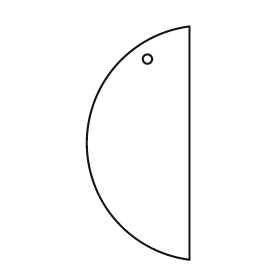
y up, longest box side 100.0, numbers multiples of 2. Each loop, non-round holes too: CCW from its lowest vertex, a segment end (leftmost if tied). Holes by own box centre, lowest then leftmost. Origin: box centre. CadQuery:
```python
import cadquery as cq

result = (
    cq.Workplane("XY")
    .moveTo(22.0, -50.0)
    .lineTo(22.0, 50.0)
    .threePointArc((-22.0, 0.0), (22.0, -50.0))
    .close()
    .moveTo(4.0, 36.0)
    .circle(2.0)
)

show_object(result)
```